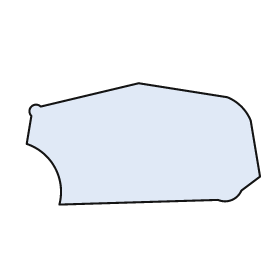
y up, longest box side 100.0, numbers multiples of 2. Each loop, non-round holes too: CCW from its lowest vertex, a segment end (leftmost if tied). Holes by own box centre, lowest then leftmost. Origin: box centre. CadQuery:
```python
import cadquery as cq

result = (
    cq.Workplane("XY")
    .moveTo(-36.0, -26.0)
    .lineTo(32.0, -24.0)
    .threePointArc((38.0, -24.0), (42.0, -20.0))
    .lineTo(50.0, -14.0)
    .lineTo(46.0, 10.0)
    .threePointArc((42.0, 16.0), (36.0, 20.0))
    .lineTo(-2.0, 26.0)
    .lineTo(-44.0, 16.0)
    .threePointArc((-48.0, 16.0), (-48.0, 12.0))
    .lineTo(-50.0, 0.0)
    .threePointArc((-38.0, -10.0), (-36.0, -26.0))
    .close()
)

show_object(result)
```